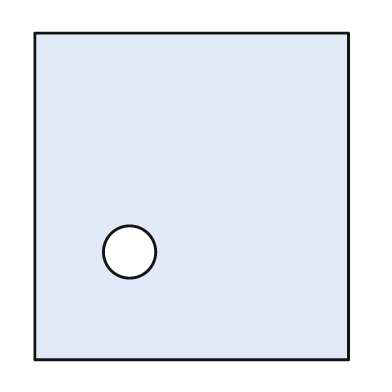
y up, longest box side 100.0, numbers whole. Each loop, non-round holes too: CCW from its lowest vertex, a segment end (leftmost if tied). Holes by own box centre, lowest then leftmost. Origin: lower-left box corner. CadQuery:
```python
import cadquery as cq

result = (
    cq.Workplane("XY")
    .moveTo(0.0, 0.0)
    .lineTo(96.0, 0.0)
    .lineTo(96.0, 100.0)
    .lineTo(0.0, 100.0)
    .close()
    .moveTo(29.0, 33.0)
    .circle(8.0)
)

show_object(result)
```